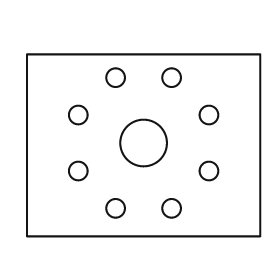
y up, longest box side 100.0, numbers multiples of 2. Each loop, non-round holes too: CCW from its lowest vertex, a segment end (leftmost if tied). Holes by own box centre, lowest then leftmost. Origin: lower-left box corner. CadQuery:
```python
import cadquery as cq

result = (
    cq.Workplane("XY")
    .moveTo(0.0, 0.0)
    .lineTo(100.0, 0.0)
    .lineTo(100.0, 78.0)
    .lineTo(0.0, 78.0)
    .close()
    .moveTo(38.0, 12.0)
    .circle(4.0)
    .moveTo(62.0, 12.0)
    .circle(4.0)
    .moveTo(22.0, 28.0)
    .circle(4.0)
    .moveTo(78.0, 28.0)
    .circle(4.0)
    .moveTo(50.0, 40.0)
    .circle(10.0)
    .moveTo(22.0, 52.0)
    .circle(4.0)
    .moveTo(78.0, 52.0)
    .circle(4.0)
    .moveTo(38.0, 68.0)
    .circle(4.0)
    .moveTo(62.0, 68.0)
    .circle(4.0)
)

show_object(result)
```